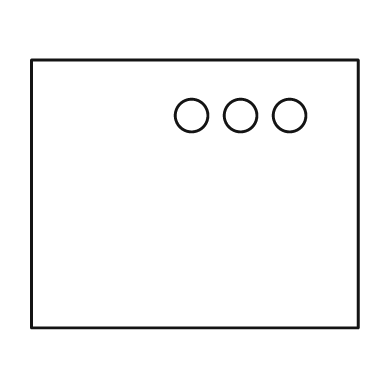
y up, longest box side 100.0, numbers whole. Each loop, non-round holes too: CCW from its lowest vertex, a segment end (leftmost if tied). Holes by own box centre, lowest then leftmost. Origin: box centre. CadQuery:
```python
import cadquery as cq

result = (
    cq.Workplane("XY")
    .moveTo(-50.0, -41.0)
    .lineTo(50.0, -41.0)
    .lineTo(50.0, 41.0)
    .lineTo(-50.0, 41.0)
    .close()
    .moveTo(-1.0, 24.0)
    .circle(5.0)
    .moveTo(14.0, 24.0)
    .circle(5.0)
    .moveTo(29.0, 24.0)
    .circle(5.0)
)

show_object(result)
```